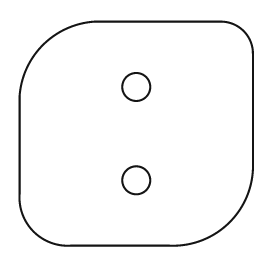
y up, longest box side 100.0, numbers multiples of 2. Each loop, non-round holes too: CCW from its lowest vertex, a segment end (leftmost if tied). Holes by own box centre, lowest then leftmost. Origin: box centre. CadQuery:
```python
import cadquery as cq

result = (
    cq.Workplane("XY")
    .moveTo(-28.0, -48.0)
    .lineTo(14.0, -48.0)
    .threePointArc((40.0, -38.0), (50.0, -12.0))
    .lineTo(50.0, 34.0)
    .threePointArc((46.0, 44.0), (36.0, 48.0))
    .lineTo(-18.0, 48.0)
    .threePointArc((-40.0, 38.0), (-50.0, 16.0))
    .lineTo(-50.0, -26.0)
    .threePointArc((-44.0, -42.0), (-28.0, -48.0))
    .close()
    .moveTo(0.0, -20.0)
    .circle(6.0)
    .moveTo(0.0, 20.0)
    .circle(6.0)
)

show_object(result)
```